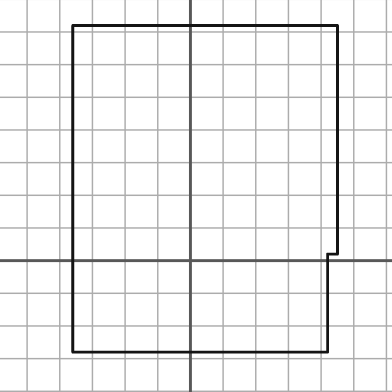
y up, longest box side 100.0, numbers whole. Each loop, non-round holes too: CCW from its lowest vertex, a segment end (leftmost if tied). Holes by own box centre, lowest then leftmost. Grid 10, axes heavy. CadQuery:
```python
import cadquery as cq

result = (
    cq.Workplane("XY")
    .moveTo(-36.0, -28.0)
    .lineTo(42.0, -28.0)
    .lineTo(42.0, 2.0)
    .lineTo(45.0, 2.0)
    .lineTo(45.0, 72.0)
    .lineTo(-36.0, 72.0)
    .close()
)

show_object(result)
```